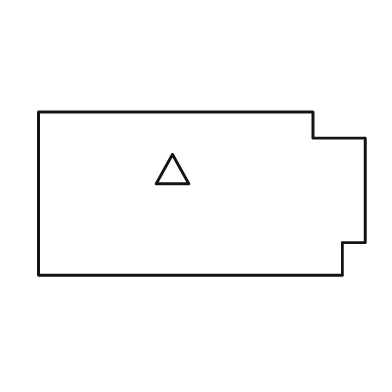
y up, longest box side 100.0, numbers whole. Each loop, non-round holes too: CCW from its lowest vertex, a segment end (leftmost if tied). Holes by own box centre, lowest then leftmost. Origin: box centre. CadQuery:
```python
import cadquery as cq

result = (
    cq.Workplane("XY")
    .moveTo(-50.0, -25.0)
    .lineTo(43.0, -25.0)
    .lineTo(43.0, -15.0)
    .lineTo(50.0, -15.0)
    .lineTo(50.0, 17.0)
    .lineTo(34.0, 17.0)
    .lineTo(34.0, 25.0)
    .lineTo(-50.0, 25.0)
    .close()
    .moveTo(-14.0, 3.0)
    .lineTo(-4.0, 3.0)
    .lineTo(-9.0, 12.0)
    .close()
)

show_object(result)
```